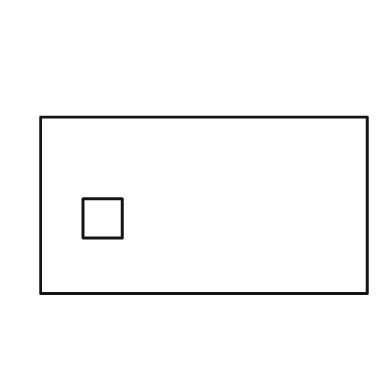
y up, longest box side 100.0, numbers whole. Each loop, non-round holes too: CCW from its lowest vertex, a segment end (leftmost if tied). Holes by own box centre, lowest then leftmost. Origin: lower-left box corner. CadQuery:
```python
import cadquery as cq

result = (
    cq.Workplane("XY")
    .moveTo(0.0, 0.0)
    .lineTo(100.0, 0.0)
    .lineTo(100.0, 54.0)
    .lineTo(0.0, 54.0)
    .close()
    .moveTo(13.0, 17.0)
    .lineTo(25.0, 17.0)
    .lineTo(25.0, 29.0)
    .lineTo(13.0, 29.0)
    .close()
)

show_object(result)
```